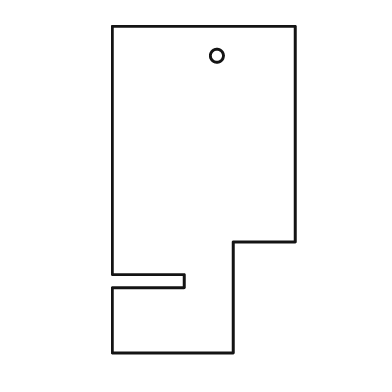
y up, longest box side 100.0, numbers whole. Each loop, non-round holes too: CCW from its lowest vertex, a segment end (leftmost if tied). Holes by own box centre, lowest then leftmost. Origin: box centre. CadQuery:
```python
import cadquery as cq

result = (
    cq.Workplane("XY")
    .moveTo(-28.0, -50.0)
    .lineTo(9.0, -50.0)
    .lineTo(9.0, -16.0)
    .lineTo(28.0, -16.0)
    .lineTo(28.0, 50.0)
    .lineTo(-28.0, 50.0)
    .lineTo(-28.0, -26.0)
    .lineTo(-6.0, -26.0)
    .lineTo(-6.0, -30.0)
    .lineTo(-28.0, -30.0)
    .close()
    .moveTo(4.0, 41.0)
    .circle(2.0)
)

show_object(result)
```